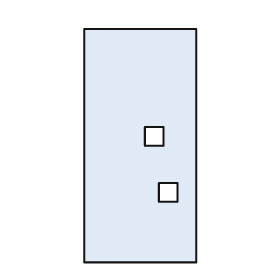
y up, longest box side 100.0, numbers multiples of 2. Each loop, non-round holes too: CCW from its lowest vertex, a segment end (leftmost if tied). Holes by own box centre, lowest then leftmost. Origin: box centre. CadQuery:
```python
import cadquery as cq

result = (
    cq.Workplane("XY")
    .moveTo(-24.0, -50.0)
    .lineTo(24.0, -50.0)
    .lineTo(24.0, 50.0)
    .lineTo(-24.0, 50.0)
    .close()
    .moveTo(8.0, -24.0)
    .lineTo(16.0, -24.0)
    .lineTo(16.0, -16.0)
    .lineTo(8.0, -16.0)
    .close()
    .moveTo(2.0, 0.0)
    .lineTo(10.0, 0.0)
    .lineTo(10.0, 8.0)
    .lineTo(2.0, 8.0)
    .close()
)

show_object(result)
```